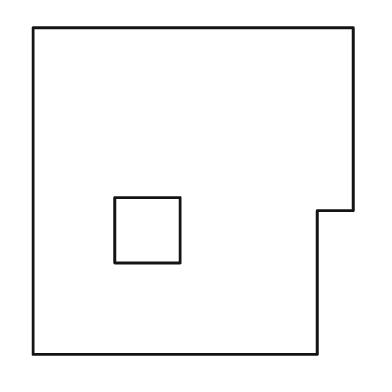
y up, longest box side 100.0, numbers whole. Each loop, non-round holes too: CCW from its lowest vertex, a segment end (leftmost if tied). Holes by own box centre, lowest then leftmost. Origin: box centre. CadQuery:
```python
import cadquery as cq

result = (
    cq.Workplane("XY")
    .moveTo(-49.0, -50.0)
    .lineTo(38.0, -50.0)
    .lineTo(38.0, -6.0)
    .lineTo(49.0, -6.0)
    .lineTo(49.0, 50.0)
    .lineTo(-49.0, 50.0)
    .close()
    .moveTo(-24.0, -22.0)
    .lineTo(-4.0, -22.0)
    .lineTo(-4.0, -2.0)
    .lineTo(-24.0, -2.0)
    .close()
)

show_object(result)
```